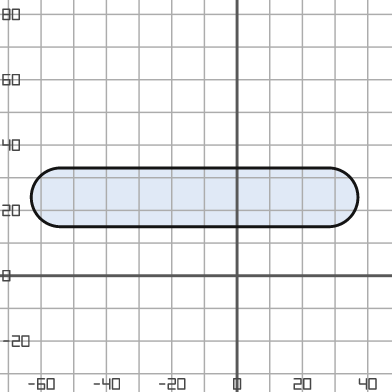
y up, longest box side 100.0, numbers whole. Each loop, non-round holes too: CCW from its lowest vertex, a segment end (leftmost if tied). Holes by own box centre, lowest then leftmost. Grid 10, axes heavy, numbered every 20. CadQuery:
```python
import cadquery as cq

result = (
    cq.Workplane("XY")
    .moveTo(-54.0, 15.0)
    .lineTo(28.0, 15.0)
    .threePointArc((37.0, 24.0), (28.0, 33.0))
    .lineTo(-54.0, 33.0)
    .threePointArc((-63.0, 24.0), (-54.0, 15.0))
    .close()
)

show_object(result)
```